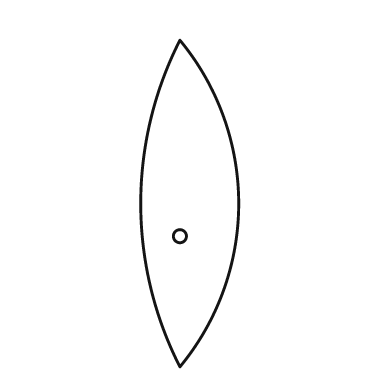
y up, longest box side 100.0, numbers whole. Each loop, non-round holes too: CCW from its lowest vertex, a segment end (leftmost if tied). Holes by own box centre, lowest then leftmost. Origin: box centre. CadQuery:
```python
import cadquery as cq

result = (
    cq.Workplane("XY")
    .moveTo(-3.0, -50.0)
    .threePointArc((15.0, 0.0), (-3.0, 50.0))
    .threePointArc((-15.0, 0.0), (-3.0, -50.0))
    .close()
    .moveTo(-3.0, -10.0)
    .circle(2.0)
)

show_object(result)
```